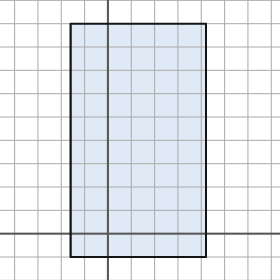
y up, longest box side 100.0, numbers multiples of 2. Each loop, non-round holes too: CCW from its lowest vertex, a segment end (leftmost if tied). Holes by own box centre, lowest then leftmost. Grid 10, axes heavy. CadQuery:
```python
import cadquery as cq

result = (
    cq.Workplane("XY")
    .moveTo(-16.0, -10.0)
    .lineTo(42.0, -10.0)
    .lineTo(42.0, 90.0)
    .lineTo(-16.0, 90.0)
    .close()
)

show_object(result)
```